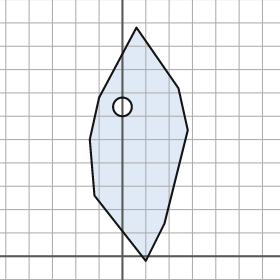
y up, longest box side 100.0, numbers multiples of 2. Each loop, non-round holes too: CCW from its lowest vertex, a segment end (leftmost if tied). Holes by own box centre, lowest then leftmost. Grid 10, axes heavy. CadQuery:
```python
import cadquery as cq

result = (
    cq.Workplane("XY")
    .moveTo(10.0, -2.0)
    .lineTo(18.0, 14.0)
    .lineTo(28.0, 54.0)
    .lineTo(24.0, 72.0)
    .lineTo(6.0, 98.0)
    .lineTo(-10.0, 68.0)
    .lineTo(-14.0, 50.0)
    .lineTo(-12.0, 26.0)
    .close()
    .moveTo(0.0, 64.0)
    .circle(4.0)
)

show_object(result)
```